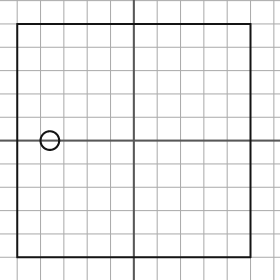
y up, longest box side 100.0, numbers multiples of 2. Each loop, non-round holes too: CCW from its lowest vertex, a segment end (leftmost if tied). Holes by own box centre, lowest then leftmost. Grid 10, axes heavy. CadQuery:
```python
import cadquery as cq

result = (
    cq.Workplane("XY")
    .moveTo(-50.0, -50.0)
    .lineTo(50.0, -50.0)
    .lineTo(50.0, 50.0)
    .lineTo(-50.0, 50.0)
    .close()
    .moveTo(-36.0, 0.0)
    .circle(4.0)
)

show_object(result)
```